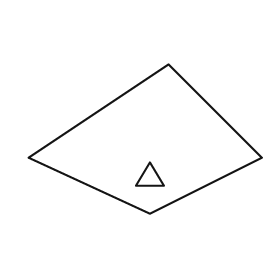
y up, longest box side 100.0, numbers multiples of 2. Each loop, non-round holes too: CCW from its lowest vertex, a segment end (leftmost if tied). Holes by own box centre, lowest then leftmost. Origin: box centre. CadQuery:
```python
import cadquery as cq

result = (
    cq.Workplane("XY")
    .moveTo(2.0, -32.0)
    .lineTo(50.0, -8.0)
    .lineTo(10.0, 32.0)
    .lineTo(-50.0, -8.0)
    .close()
    .moveTo(-4.0, -20.0)
    .lineTo(8.0, -20.0)
    .lineTo(2.0, -10.0)
    .close()
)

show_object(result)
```